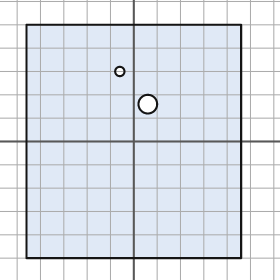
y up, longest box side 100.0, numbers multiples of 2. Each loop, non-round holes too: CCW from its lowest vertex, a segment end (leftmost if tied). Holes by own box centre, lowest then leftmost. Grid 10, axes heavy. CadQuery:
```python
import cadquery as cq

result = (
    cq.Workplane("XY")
    .moveTo(-46.0, -50.0)
    .lineTo(46.0, -50.0)
    .lineTo(46.0, 50.0)
    .lineTo(-46.0, 50.0)
    .close()
    .moveTo(6.0, 16.0)
    .circle(4.0)
    .moveTo(-6.0, 30.0)
    .circle(2.0)
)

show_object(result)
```